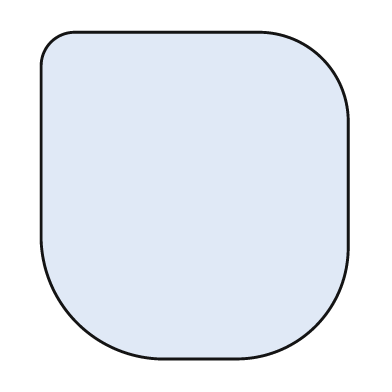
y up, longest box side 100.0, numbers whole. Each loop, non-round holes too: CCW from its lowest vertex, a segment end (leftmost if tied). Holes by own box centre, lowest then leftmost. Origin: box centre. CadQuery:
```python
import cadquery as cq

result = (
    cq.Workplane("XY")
    .moveTo(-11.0, -50.0)
    .lineTo(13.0, -50.0)
    .threePointArc((37.0, -40.0), (47.0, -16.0))
    .lineTo(47.0, 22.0)
    .threePointArc((39.0, 42.0), (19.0, 50.0))
    .lineTo(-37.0, 50.0)
    .threePointArc((-44.0, 47.0), (-47.0, 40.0))
    .lineTo(-47.0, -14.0)
    .threePointArc((-36.0, -39.0), (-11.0, -50.0))
    .close()
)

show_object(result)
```